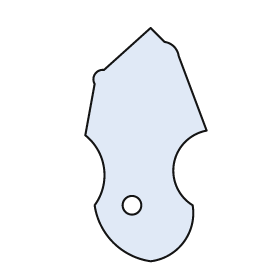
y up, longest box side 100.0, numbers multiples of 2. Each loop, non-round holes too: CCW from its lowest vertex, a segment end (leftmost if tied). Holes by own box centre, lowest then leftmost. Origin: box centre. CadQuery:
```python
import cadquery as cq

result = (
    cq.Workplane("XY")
    .moveTo(2.0, -50.0)
    .threePointArc((16.0, -42.0), (20.0, -26.0))
    .threePointArc((12.0, -8.0), (26.0, 6.0))
    .lineTo(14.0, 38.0)
    .threePointArc((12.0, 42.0), (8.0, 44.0))
    .lineTo(2.0, 50.0)
    .lineTo(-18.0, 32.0)
    .threePointArc((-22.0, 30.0), (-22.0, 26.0))
    .lineTo(-26.0, 4.0)
    .threePointArc((-18.0, -10.0), (-22.0, -26.0))
    .threePointArc((-14.0, -42.0), (2.0, -50.0))
    .close()
    .moveTo(-6.0, -26.0)
    .circle(4.0)
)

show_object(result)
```